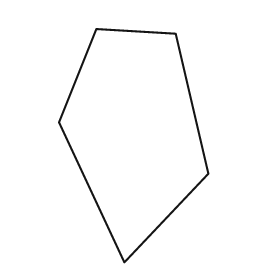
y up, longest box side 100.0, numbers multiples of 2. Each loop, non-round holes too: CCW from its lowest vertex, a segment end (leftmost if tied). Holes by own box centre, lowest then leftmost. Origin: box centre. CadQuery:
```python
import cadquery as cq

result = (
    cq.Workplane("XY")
    .moveTo(-4.0, -50.0)
    .lineTo(32.0, -12.0)
    .lineTo(18.0, 48.0)
    .lineTo(-16.0, 50.0)
    .lineTo(-32.0, 10.0)
    .close()
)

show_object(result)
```